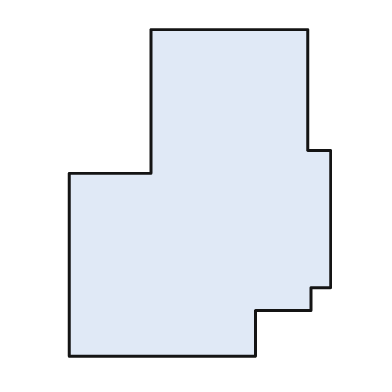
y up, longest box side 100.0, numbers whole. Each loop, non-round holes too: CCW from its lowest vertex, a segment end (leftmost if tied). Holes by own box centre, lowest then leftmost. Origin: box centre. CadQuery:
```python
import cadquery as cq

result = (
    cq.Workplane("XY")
    .moveTo(-40.0, -50.0)
    .lineTo(17.0, -50.0)
    .lineTo(17.0, -36.0)
    .lineTo(34.0, -36.0)
    .lineTo(34.0, -29.0)
    .lineTo(40.0, -29.0)
    .lineTo(40.0, 13.0)
    .lineTo(33.0, 13.0)
    .lineTo(33.0, 50.0)
    .lineTo(-15.0, 50.0)
    .lineTo(-15.0, 6.0)
    .lineTo(-40.0, 6.0)
    .close()
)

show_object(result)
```